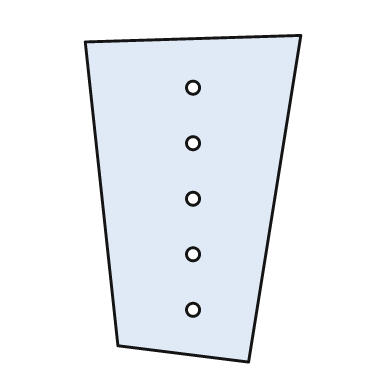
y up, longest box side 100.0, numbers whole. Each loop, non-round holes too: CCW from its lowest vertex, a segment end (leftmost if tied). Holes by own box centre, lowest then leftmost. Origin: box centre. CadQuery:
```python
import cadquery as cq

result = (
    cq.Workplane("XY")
    .moveTo(17.0, -50.0)
    .lineTo(33.0, 50.0)
    .lineTo(-33.0, 48.0)
    .lineTo(-23.0, -45.0)
    .close()
    .moveTo(0.0, -34.0)
    .circle(2.0)
    .moveTo(0.0, -17.0)
    .circle(2.0)
    .moveTo(0.0, 0.0)
    .circle(2.0)
    .moveTo(0.0, 17.0)
    .circle(2.0)
    .moveTo(0.0, 34.0)
    .circle(2.0)
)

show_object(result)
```